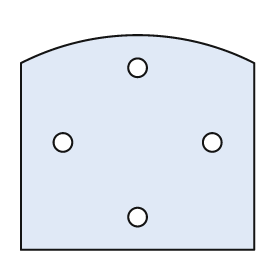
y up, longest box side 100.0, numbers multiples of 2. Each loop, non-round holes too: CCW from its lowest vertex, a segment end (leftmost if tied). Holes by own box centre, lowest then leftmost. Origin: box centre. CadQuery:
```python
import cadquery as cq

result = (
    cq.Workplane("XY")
    .moveTo(-50.0, -46.0)
    .lineTo(50.0, -46.0)
    .lineTo(50.0, 34.0)
    .threePointArc((0.0, 46.0), (-50.0, 34.0))
    .close()
    .moveTo(0.0, -32.0)
    .circle(4.0)
    .moveTo(-32.0, 0.0)
    .circle(4.0)
    .moveTo(32.0, 0.0)
    .circle(4.0)
    .moveTo(0.0, 32.0)
    .circle(4.0)
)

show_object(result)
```